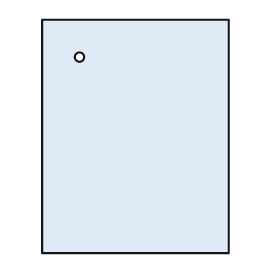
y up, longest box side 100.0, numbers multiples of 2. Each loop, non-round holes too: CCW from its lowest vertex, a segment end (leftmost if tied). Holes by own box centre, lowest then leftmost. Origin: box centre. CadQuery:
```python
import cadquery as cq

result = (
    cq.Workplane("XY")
    .moveTo(-40.0, -50.0)
    .lineTo(40.0, -50.0)
    .lineTo(40.0, 50.0)
    .lineTo(-40.0, 50.0)
    .close()
    .moveTo(-24.0, 34.0)
    .circle(2.0)
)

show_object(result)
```